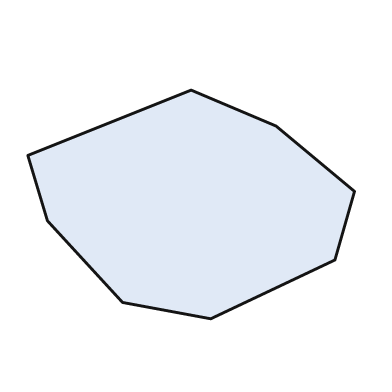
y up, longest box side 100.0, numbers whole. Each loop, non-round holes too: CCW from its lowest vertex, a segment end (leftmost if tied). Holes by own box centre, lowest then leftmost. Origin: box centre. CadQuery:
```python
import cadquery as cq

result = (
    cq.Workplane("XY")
    .moveTo(6.0, -35.0)
    .lineTo(44.0, -17.0)
    .lineTo(50.0, 4.0)
    .lineTo(26.0, 24.0)
    .lineTo(0.0, 35.0)
    .lineTo(-50.0, 15.0)
    .lineTo(-44.0, -5.0)
    .lineTo(-21.0, -30.0)
    .close()
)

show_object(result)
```